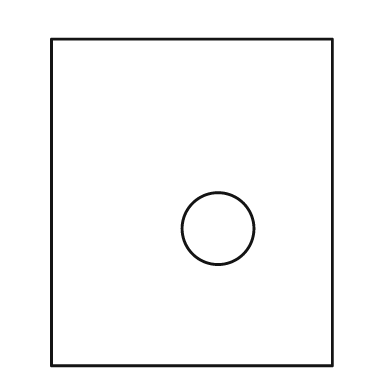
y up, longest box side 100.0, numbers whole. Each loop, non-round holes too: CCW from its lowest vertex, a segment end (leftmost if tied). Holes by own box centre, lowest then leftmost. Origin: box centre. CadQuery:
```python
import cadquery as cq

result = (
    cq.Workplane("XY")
    .moveTo(-43.0, -50.0)
    .lineTo(43.0, -50.0)
    .lineTo(43.0, 50.0)
    .lineTo(-43.0, 50.0)
    .close()
    .moveTo(8.0, -8.0)
    .circle(11.0)
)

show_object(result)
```